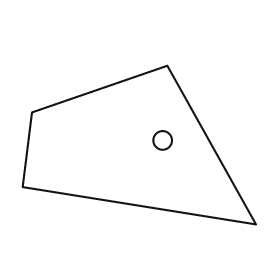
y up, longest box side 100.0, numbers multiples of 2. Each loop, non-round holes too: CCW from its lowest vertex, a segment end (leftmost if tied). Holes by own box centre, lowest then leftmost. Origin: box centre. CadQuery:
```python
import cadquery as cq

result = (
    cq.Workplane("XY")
    .moveTo(50.0, -34.0)
    .lineTo(12.0, 34.0)
    .lineTo(-46.0, 14.0)
    .lineTo(-50.0, -18.0)
    .close()
    .moveTo(10.0, 2.0)
    .circle(4.0)
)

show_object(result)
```